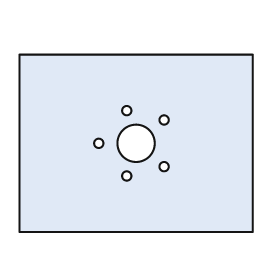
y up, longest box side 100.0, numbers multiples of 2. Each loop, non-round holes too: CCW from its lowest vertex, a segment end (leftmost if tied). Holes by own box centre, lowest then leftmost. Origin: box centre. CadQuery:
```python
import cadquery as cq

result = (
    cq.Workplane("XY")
    .moveTo(-50.0, -38.0)
    .lineTo(50.0, -38.0)
    .lineTo(50.0, 38.0)
    .lineTo(-50.0, 38.0)
    .close()
    .moveTo(-4.0, -14.0)
    .circle(2.0)
    .moveTo(12.0, -10.0)
    .circle(2.0)
    .moveTo(-16.0, 0.0)
    .circle(2.0)
    .moveTo(0.0, 0.0)
    .circle(8.0)
    .moveTo(12.0, 10.0)
    .circle(2.0)
    .moveTo(-4.0, 14.0)
    .circle(2.0)
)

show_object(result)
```